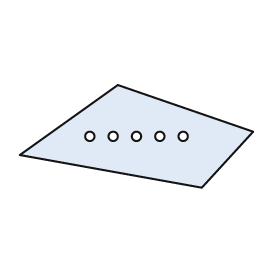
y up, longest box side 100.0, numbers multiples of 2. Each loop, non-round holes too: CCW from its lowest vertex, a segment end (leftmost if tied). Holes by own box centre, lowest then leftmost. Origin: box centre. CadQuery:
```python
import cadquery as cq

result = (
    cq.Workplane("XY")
    .moveTo(28.0, -22.0)
    .lineTo(50.0, 2.0)
    .lineTo(-8.0, 22.0)
    .lineTo(-50.0, -8.0)
    .close()
    .moveTo(-20.0, 0.0)
    .circle(2.0)
    .moveTo(-10.0, 0.0)
    .circle(2.0)
    .moveTo(0.0, 0.0)
    .circle(2.0)
    .moveTo(10.0, 0.0)
    .circle(2.0)
    .moveTo(20.0, 0.0)
    .circle(2.0)
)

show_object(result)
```